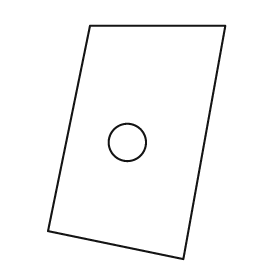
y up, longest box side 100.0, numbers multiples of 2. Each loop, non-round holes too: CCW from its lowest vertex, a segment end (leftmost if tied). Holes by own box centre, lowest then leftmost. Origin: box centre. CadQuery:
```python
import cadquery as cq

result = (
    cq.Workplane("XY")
    .moveTo(20.0, -50.0)
    .lineTo(38.0, 50.0)
    .lineTo(-20.0, 50.0)
    .lineTo(-38.0, -38.0)
    .close()
    .moveTo(-4.0, 0.0)
    .circle(8.0)
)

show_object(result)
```